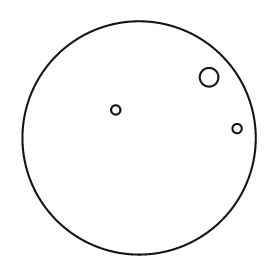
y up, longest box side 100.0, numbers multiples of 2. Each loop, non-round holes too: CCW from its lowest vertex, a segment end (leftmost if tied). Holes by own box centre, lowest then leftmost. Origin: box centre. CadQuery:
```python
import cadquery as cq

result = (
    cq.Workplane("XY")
    .moveTo(0.0, 0.0)
    .circle(50.0)
    .moveTo(42.0, 4.0)
    .circle(2.0)
    .moveTo(-10.0, 12.0)
    .circle(2.0)
    .moveTo(30.0, 26.0)
    .circle(4.0)
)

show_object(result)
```